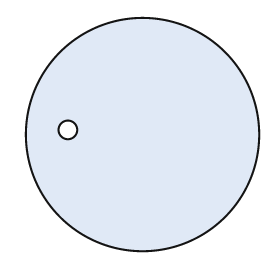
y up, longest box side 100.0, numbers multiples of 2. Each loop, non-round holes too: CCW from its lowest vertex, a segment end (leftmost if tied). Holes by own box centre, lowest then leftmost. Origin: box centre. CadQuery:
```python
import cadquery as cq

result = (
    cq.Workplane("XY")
    .moveTo(0.0, 0.0)
    .circle(50.0)
    .moveTo(-32.0, 2.0)
    .circle(4.0)
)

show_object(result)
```